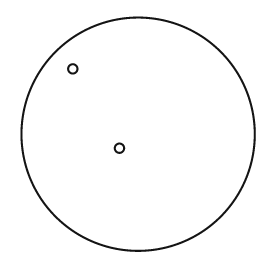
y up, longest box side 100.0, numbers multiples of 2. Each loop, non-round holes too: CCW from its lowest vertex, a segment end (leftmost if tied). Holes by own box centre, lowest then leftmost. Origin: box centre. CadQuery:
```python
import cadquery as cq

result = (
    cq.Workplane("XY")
    .moveTo(0.0, 0.0)
    .circle(50.0)
    .moveTo(-8.0, -6.0)
    .circle(2.0)
    .moveTo(-28.0, 28.0)
    .circle(2.0)
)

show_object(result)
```